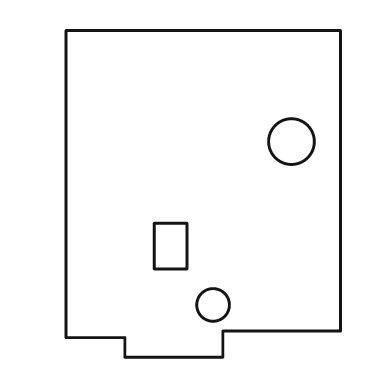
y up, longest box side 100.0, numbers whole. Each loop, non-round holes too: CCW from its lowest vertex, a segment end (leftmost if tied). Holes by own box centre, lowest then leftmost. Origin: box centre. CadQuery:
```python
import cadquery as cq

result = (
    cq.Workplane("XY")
    .moveTo(-24.0, -50.0)
    .lineTo(6.0, -50.0)
    .lineTo(6.0, -42.0)
    .lineTo(42.0, -42.0)
    .lineTo(42.0, 50.0)
    .lineTo(-42.0, 50.0)
    .lineTo(-42.0, -44.0)
    .lineTo(-24.0, -44.0)
    .close()
    .moveTo(3.0, -34.0)
    .circle(5.0)
    .moveTo(-15.0, -23.0)
    .lineTo(-5.0, -23.0)
    .lineTo(-5.0, -9.0)
    .lineTo(-15.0, -9.0)
    .close()
    .moveTo(27.0, 16.0)
    .circle(7.0)
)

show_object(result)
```